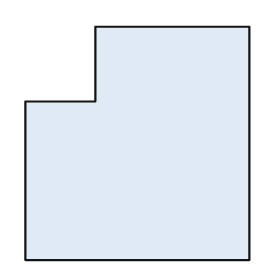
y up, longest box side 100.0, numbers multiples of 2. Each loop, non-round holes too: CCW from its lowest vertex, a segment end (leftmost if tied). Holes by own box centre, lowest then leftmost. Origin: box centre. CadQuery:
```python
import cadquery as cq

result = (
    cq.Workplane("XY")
    .moveTo(-48.0, -50.0)
    .lineTo(48.0, -50.0)
    .lineTo(48.0, 50.0)
    .lineTo(-18.0, 50.0)
    .lineTo(-18.0, 18.0)
    .lineTo(-48.0, 18.0)
    .close()
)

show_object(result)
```